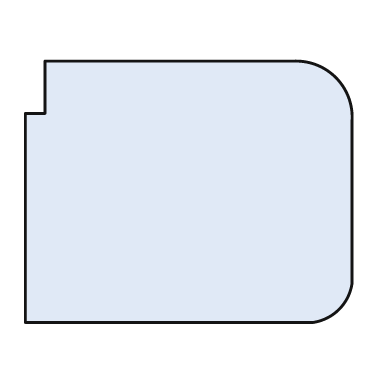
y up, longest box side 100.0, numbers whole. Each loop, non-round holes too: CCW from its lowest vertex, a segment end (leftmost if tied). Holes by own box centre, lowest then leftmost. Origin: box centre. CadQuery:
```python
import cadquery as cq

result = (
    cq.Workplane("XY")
    .moveTo(-50.0, -40.0)
    .lineTo(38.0, -40.0)
    .threePointArc((46.0, -36.0), (50.0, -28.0))
    .lineTo(50.0, 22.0)
    .threePointArc((45.0, 35.0), (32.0, 40.0))
    .lineTo(-44.0, 40.0)
    .lineTo(-44.0, 24.0)
    .lineTo(-50.0, 24.0)
    .close()
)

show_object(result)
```